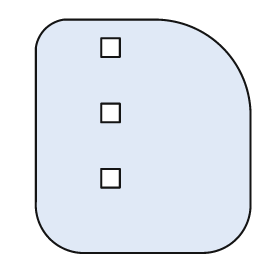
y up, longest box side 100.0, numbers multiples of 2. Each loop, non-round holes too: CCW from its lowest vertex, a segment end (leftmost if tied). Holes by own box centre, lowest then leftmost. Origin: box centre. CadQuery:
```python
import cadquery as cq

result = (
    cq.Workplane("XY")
    .moveTo(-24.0, -50.0)
    .lineTo(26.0, -50.0)
    .threePointArc((40.0, -44.0), (46.0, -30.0))
    .lineTo(46.0, 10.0)
    .threePointArc((34.0, 38.0), (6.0, 50.0))
    .lineTo(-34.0, 50.0)
    .threePointArc((-42.0, 46.0), (-46.0, 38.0))
    .lineTo(-46.0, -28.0)
    .threePointArc((-40.0, -44.0), (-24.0, -50.0))
    .close()
    .moveTo(-18.0, -22.0)
    .lineTo(-10.0, -22.0)
    .lineTo(-10.0, -14.0)
    .lineTo(-18.0, -14.0)
    .close()
    .moveTo(-18.0, 6.0)
    .lineTo(-10.0, 6.0)
    .lineTo(-10.0, 14.0)
    .lineTo(-18.0, 14.0)
    .close()
    .moveTo(-18.0, 34.0)
    .lineTo(-10.0, 34.0)
    .lineTo(-10.0, 42.0)
    .lineTo(-18.0, 42.0)
    .close()
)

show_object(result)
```